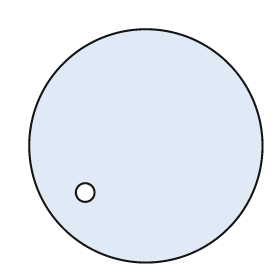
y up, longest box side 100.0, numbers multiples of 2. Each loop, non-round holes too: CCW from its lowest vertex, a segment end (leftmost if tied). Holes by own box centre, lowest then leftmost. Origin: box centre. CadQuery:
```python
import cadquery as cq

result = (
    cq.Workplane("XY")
    .moveTo(0.0, 0.0)
    .circle(50.0)
    .moveTo(-26.0, -20.0)
    .circle(4.0)
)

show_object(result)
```